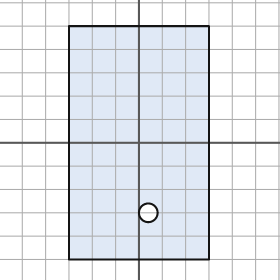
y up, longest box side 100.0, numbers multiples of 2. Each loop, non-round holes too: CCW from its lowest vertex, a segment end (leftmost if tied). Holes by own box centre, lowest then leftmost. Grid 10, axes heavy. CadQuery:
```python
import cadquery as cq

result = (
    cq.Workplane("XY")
    .moveTo(-30.0, -50.0)
    .lineTo(30.0, -50.0)
    .lineTo(30.0, 50.0)
    .lineTo(-30.0, 50.0)
    .close()
    .moveTo(4.0, -30.0)
    .circle(4.0)
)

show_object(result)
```